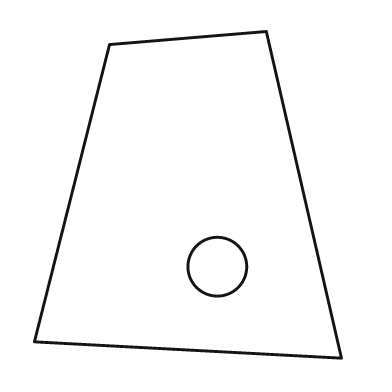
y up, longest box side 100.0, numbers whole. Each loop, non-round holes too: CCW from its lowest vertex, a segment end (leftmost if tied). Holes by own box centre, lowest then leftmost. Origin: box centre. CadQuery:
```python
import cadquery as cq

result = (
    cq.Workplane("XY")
    .moveTo(47.0, -50.0)
    .lineTo(24.0, 50.0)
    .lineTo(-24.0, 46.0)
    .lineTo(-47.0, -45.0)
    .close()
    .moveTo(9.0, -22.0)
    .circle(9.0)
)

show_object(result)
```